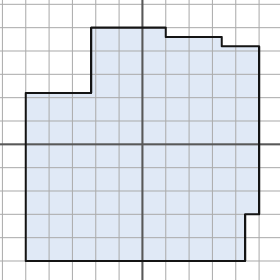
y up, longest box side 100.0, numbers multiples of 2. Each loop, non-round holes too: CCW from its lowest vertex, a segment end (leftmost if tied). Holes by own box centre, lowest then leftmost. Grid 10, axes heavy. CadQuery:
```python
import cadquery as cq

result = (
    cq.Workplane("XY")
    .moveTo(-50.0, -50.0)
    .lineTo(44.0, -50.0)
    .lineTo(44.0, -30.0)
    .lineTo(50.0, -30.0)
    .lineTo(50.0, 42.0)
    .lineTo(34.0, 42.0)
    .lineTo(34.0, 46.0)
    .lineTo(10.0, 46.0)
    .lineTo(10.0, 50.0)
    .lineTo(-22.0, 50.0)
    .lineTo(-22.0, 22.0)
    .lineTo(-50.0, 22.0)
    .close()
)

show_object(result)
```